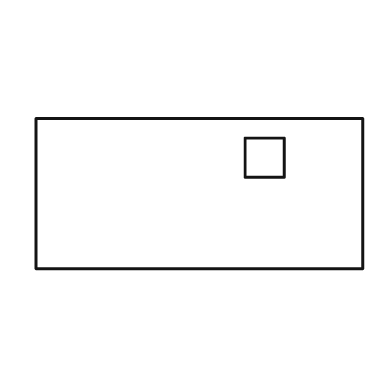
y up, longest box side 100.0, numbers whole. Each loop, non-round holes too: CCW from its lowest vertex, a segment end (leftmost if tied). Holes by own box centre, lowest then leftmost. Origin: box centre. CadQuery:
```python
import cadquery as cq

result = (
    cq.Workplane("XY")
    .moveTo(-50.0, -23.0)
    .lineTo(50.0, -23.0)
    .lineTo(50.0, 23.0)
    .lineTo(-50.0, 23.0)
    .close()
    .moveTo(14.0, 5.0)
    .lineTo(26.0, 5.0)
    .lineTo(26.0, 17.0)
    .lineTo(14.0, 17.0)
    .close()
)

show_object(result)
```